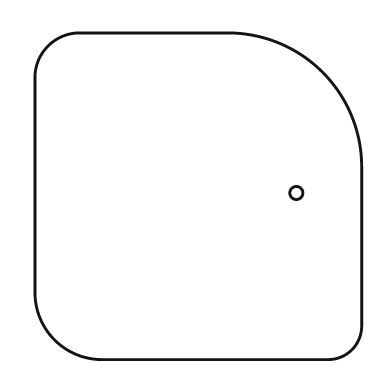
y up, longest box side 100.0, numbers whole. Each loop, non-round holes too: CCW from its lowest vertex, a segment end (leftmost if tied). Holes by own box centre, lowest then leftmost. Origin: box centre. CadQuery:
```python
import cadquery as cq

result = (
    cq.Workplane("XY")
    .moveTo(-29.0, -50.0)
    .lineTo(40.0, -50.0)
    .threePointArc((47.0, -47.0), (50.0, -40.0))
    .lineTo(50.0, 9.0)
    .threePointArc((38.0, 38.0), (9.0, 50.0))
    .lineTo(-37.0, 50.0)
    .threePointArc((-46.0, 46.0), (-50.0, 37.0))
    .lineTo(-50.0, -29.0)
    .threePointArc((-44.0, -44.0), (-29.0, -50.0))
    .close()
    .moveTo(30.0, 1.0)
    .circle(2.0)
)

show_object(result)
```